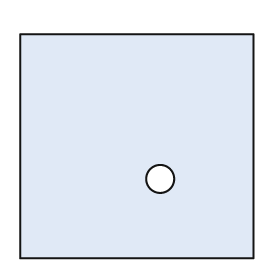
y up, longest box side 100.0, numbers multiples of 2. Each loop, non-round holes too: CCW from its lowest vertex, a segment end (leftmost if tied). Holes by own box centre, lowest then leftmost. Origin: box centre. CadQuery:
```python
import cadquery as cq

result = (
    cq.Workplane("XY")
    .moveTo(-50.0, -48.0)
    .lineTo(50.0, -48.0)
    .lineTo(50.0, 48.0)
    .lineTo(-50.0, 48.0)
    .close()
    .moveTo(10.0, -14.0)
    .circle(6.0)
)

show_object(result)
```